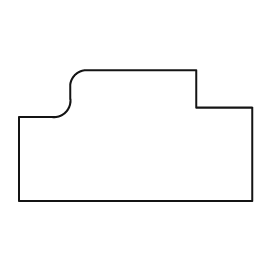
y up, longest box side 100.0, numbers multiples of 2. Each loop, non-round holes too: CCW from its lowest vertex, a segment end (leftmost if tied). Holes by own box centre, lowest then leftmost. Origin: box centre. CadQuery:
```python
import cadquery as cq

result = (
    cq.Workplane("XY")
    .moveTo(-50.0, -28.0)
    .lineTo(50.0, -28.0)
    .lineTo(50.0, 12.0)
    .lineTo(26.0, 12.0)
    .lineTo(26.0, 28.0)
    .lineTo(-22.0, 28.0)
    .threePointArc((-26.0, 26.0), (-28.0, 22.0))
    .lineTo(-28.0, 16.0)
    .threePointArc((-30.0, 10.0), (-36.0, 8.0))
    .lineTo(-50.0, 8.0)
    .close()
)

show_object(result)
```